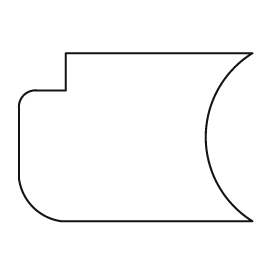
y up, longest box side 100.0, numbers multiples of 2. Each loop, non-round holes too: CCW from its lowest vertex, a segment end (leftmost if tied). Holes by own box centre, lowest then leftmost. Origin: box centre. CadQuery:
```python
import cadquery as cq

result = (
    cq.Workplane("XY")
    .moveTo(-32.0, -36.0)
    .lineTo(50.0, -36.0)
    .threePointArc((30.0, 0.0), (50.0, 36.0))
    .lineTo(-30.0, 36.0)
    .lineTo(-30.0, 20.0)
    .lineTo(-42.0, 20.0)
    .threePointArc((-48.0, 18.0), (-50.0, 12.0))
    .lineTo(-50.0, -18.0)
    .threePointArc((-44.0, -30.0), (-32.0, -36.0))
    .close()
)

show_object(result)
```